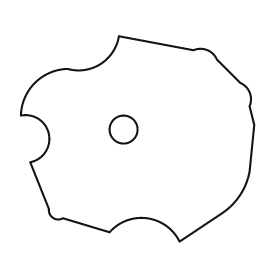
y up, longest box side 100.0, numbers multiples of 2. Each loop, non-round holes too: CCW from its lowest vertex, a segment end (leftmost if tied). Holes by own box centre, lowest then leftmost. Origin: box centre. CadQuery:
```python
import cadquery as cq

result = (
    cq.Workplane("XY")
    .moveTo(18.0, -44.0)
    .lineTo(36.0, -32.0)
    .threePointArc((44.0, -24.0), (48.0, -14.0))
    .lineTo(50.0, 6.0)
    .lineTo(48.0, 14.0)
    .threePointArc((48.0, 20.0), (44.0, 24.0))
    .lineTo(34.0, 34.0)
    .threePointArc((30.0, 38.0), (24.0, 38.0))
    .lineTo(-8.0, 44.0)
    .threePointArc((-16.0, 32.0), (-30.0, 30.0))
    .threePointArc((-44.0, 24.0), (-50.0, 10.0))
    .threePointArc((-38.0, 2.0), (-46.0, -10.0))
    .lineTo(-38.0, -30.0)
    .threePointArc((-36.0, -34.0), (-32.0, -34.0))
    .lineTo(-12.0, -40.0)
    .threePointArc((4.0, -34.0), (18.0, -44.0))
    .close()
    .moveTo(-6.0, 4.0)
    .circle(6.0)
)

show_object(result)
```